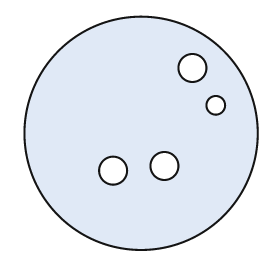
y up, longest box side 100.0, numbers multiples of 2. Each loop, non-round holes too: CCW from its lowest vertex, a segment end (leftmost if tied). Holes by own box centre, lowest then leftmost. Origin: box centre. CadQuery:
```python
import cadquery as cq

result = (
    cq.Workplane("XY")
    .moveTo(0.0, 0.0)
    .circle(50.0)
    .moveTo(-12.0, -16.0)
    .circle(6.0)
    .moveTo(10.0, -14.0)
    .circle(6.0)
    .moveTo(32.0, 12.0)
    .circle(4.0)
    .moveTo(22.0, 28.0)
    .circle(6.0)
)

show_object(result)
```